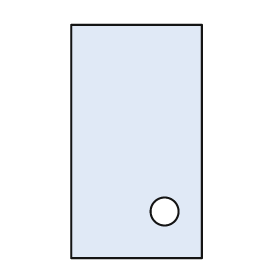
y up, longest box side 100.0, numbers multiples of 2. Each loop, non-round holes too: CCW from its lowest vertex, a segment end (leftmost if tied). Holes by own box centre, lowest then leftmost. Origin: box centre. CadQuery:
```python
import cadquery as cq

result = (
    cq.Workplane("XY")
    .moveTo(-28.0, -50.0)
    .lineTo(28.0, -50.0)
    .lineTo(28.0, 50.0)
    .lineTo(-28.0, 50.0)
    .close()
    .moveTo(12.0, -30.0)
    .circle(6.0)
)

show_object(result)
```